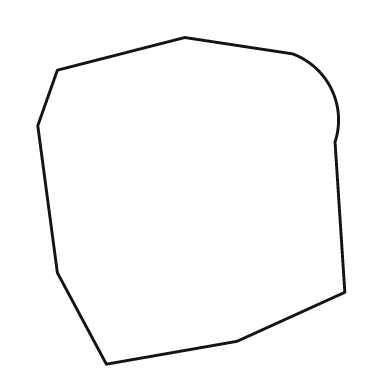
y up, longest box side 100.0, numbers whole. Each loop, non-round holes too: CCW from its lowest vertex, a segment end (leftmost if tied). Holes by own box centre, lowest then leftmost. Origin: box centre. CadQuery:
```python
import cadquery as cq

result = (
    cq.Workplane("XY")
    .moveTo(-26.0, -50.0)
    .lineTo(14.0, -43.0)
    .lineTo(47.0, -28.0)
    .lineTo(44.0, 18.0)
    .threePointArc((43.0, 34.0), (31.0, 45.0))
    .lineTo(-2.0, 50.0)
    .lineTo(-41.0, 40.0)
    .lineTo(-47.0, 23.0)
    .lineTo(-41.0, -22.0)
    .close()
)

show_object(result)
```